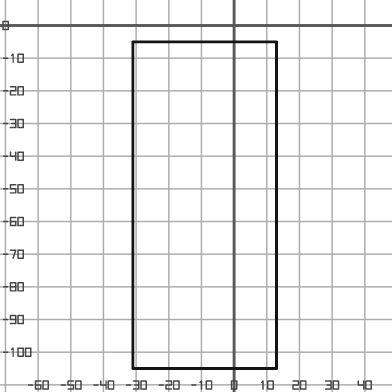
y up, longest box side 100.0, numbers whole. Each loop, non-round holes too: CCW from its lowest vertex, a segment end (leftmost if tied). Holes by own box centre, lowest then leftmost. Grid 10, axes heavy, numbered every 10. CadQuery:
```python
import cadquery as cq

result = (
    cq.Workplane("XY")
    .moveTo(-31.0, -105.0)
    .lineTo(13.0, -105.0)
    .lineTo(13.0, -5.0)
    .lineTo(-31.0, -5.0)
    .close()
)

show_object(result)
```